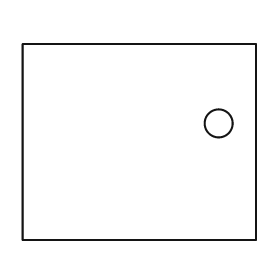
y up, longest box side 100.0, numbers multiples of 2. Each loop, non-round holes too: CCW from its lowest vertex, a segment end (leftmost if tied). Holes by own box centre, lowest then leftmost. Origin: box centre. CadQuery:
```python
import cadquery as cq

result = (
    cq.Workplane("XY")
    .moveTo(-50.0, -42.0)
    .lineTo(50.0, -42.0)
    .lineTo(50.0, 42.0)
    .lineTo(-50.0, 42.0)
    .close()
    .moveTo(34.0, 8.0)
    .circle(6.0)
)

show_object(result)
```